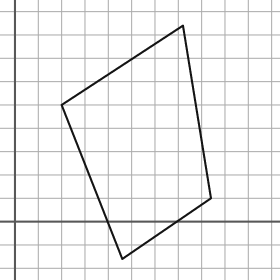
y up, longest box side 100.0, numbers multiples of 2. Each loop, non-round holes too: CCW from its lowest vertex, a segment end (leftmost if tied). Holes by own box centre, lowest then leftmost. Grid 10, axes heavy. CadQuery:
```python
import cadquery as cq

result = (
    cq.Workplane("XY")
    .moveTo(46.0, -16.0)
    .lineTo(84.0, 10.0)
    .lineTo(72.0, 84.0)
    .lineTo(20.0, 50.0)
    .close()
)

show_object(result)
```